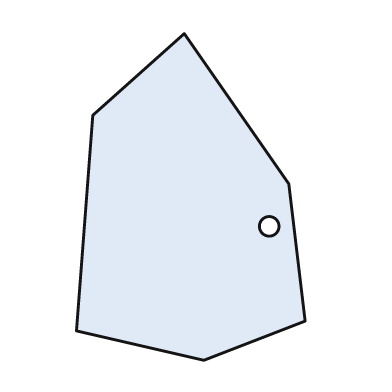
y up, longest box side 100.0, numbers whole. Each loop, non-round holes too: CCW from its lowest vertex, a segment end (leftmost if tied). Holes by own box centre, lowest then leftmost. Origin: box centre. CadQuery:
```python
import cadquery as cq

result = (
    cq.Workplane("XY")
    .moveTo(4.0, -50.0)
    .lineTo(35.0, -38.0)
    .lineTo(30.0, 4.0)
    .lineTo(-2.0, 50.0)
    .lineTo(-30.0, 25.0)
    .lineTo(-35.0, -41.0)
    .close()
    .moveTo(24.0, -9.0)
    .circle(3.0)
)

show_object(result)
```